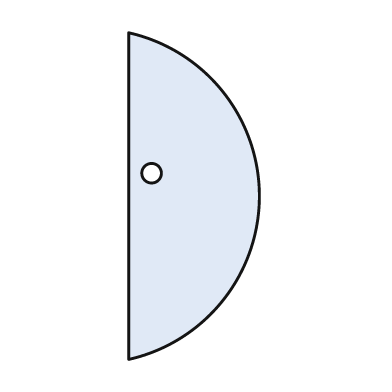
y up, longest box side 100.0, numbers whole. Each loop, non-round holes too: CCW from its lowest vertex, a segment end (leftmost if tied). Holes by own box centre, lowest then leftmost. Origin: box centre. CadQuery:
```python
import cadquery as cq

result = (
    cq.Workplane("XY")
    .moveTo(-20.0, -50.0)
    .threePointArc((20.0, 0.0), (-20.0, 50.0))
    .close()
    .moveTo(-13.0, 7.0)
    .circle(3.0)
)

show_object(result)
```